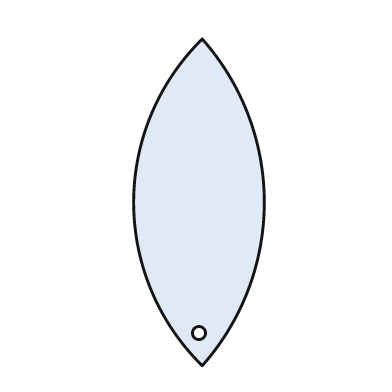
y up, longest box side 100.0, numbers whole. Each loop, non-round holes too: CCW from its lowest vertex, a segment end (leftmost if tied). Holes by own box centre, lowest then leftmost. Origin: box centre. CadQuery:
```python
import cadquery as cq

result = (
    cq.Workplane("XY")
    .moveTo(1.0, -50.0)
    .threePointArc((20.0, 0.0), (1.0, 50.0))
    .threePointArc((-20.0, 0.0), (1.0, -50.0))
    .close()
    .moveTo(0.0, -40.0)
    .circle(2.0)
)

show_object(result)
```